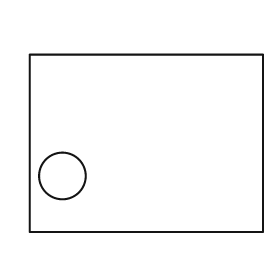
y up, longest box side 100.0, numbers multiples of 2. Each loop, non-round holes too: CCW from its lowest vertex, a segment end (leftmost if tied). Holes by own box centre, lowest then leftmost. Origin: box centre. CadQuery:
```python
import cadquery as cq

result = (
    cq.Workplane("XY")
    .moveTo(-50.0, -38.0)
    .lineTo(50.0, -38.0)
    .lineTo(50.0, 38.0)
    .lineTo(-50.0, 38.0)
    .close()
    .moveTo(-36.0, -14.0)
    .circle(10.0)
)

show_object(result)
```